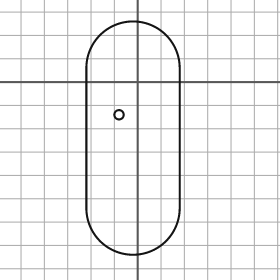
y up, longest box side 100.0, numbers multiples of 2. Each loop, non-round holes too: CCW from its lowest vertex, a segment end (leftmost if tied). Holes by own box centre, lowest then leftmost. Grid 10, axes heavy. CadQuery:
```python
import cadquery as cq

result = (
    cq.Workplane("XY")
    .moveTo(-22.0, -54.0)
    .threePointArc((-2.0, -74.0), (18.0, -54.0))
    .lineTo(18.0, 6.0)
    .threePointArc((-2.0, 26.0), (-22.0, 6.0))
    .close()
    .moveTo(-8.0, -14.0)
    .circle(2.0)
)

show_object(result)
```